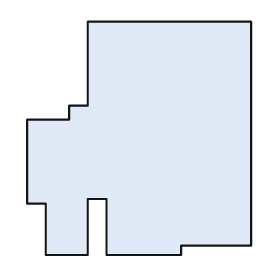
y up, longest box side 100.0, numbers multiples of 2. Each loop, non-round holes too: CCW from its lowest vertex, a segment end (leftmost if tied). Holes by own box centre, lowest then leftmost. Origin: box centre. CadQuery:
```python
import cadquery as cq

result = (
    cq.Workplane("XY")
    .moveTo(-40.0, -50.0)
    .lineTo(-22.0, -50.0)
    .lineTo(-22.0, -26.0)
    .lineTo(-14.0, -26.0)
    .lineTo(-14.0, -50.0)
    .lineTo(18.0, -50.0)
    .lineTo(18.0, -46.0)
    .lineTo(48.0, -46.0)
    .lineTo(48.0, 50.0)
    .lineTo(-22.0, 50.0)
    .lineTo(-22.0, 14.0)
    .lineTo(-30.0, 14.0)
    .lineTo(-30.0, 8.0)
    .lineTo(-48.0, 8.0)
    .lineTo(-48.0, -28.0)
    .lineTo(-40.0, -28.0)
    .close()
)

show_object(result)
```